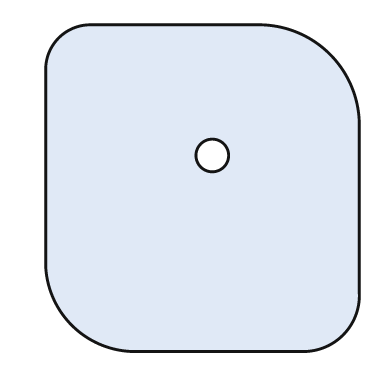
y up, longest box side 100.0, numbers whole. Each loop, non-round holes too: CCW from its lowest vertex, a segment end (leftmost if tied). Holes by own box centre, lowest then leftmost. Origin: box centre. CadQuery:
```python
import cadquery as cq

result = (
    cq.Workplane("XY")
    .moveTo(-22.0, -50.0)
    .lineTo(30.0, -50.0)
    .threePointArc((43.0, -45.0), (48.0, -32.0))
    .lineTo(48.0, 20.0)
    .threePointArc((39.0, 41.0), (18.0, 50.0))
    .lineTo(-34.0, 50.0)
    .threePointArc((-44.0, 46.0), (-48.0, 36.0))
    .lineTo(-48.0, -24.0)
    .threePointArc((-40.0, -42.0), (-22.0, -50.0))
    .close()
    .moveTo(3.0, 10.0)
    .circle(5.0)
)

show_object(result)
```